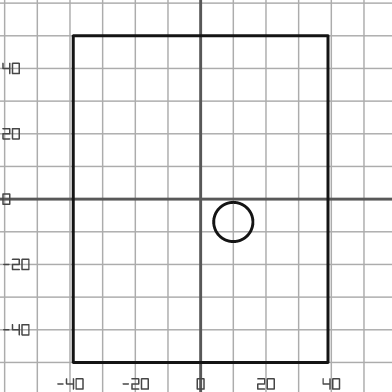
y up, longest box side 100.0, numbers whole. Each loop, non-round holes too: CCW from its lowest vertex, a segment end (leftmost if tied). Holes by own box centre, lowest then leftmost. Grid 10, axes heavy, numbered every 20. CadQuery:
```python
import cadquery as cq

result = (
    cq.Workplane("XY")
    .moveTo(-39.0, -50.0)
    .lineTo(39.0, -50.0)
    .lineTo(39.0, 50.0)
    .lineTo(-39.0, 50.0)
    .close()
    .moveTo(10.0, -7.0)
    .circle(6.0)
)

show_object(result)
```